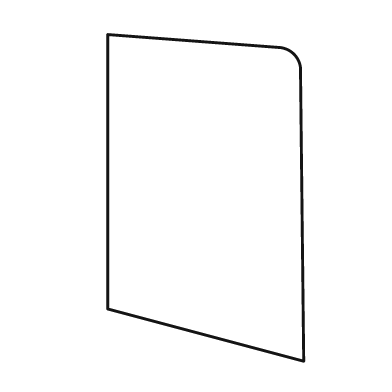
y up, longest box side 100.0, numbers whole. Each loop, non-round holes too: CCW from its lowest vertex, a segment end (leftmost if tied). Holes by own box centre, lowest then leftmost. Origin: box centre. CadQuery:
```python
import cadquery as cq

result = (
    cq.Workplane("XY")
    .moveTo(30.0, -50.0)
    .lineTo(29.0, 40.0)
    .threePointArc((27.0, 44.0), (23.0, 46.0))
    .lineTo(-30.0, 50.0)
    .lineTo(-30.0, -34.0)
    .close()
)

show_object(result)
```